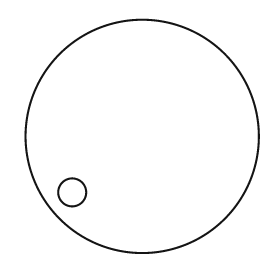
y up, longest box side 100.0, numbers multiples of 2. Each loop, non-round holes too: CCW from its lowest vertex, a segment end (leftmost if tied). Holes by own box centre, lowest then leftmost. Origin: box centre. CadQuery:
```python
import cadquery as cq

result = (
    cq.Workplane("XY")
    .moveTo(0.0, 0.0)
    .circle(50.0)
    .moveTo(-30.0, -24.0)
    .circle(6.0)
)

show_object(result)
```